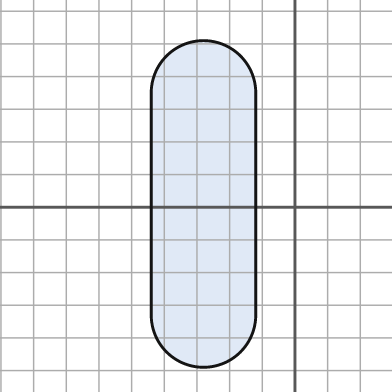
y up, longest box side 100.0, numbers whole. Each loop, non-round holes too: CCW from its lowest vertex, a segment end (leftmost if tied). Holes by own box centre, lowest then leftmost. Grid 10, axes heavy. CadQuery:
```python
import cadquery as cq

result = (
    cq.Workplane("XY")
    .moveTo(-44.0, -33.0)
    .threePointArc((-28.0, -49.0), (-12.0, -33.0))
    .lineTo(-12.0, 35.0)
    .threePointArc((-28.0, 51.0), (-44.0, 35.0))
    .close()
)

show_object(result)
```